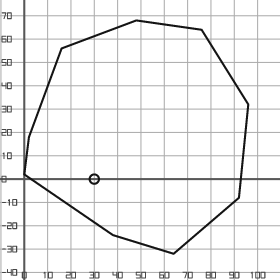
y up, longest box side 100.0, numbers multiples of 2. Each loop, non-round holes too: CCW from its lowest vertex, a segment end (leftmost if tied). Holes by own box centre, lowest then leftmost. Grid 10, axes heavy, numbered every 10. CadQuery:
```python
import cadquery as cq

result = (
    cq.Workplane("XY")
    .moveTo(64.0, -32.0)
    .lineTo(92.0, -8.0)
    .lineTo(96.0, 32.0)
    .lineTo(76.0, 64.0)
    .lineTo(48.0, 68.0)
    .lineTo(16.0, 56.0)
    .lineTo(2.0, 18.0)
    .lineTo(0.0, 2.0)
    .lineTo(38.0, -24.0)
    .close()
    .moveTo(30.0, 0.0)
    .circle(2.0)
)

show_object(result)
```